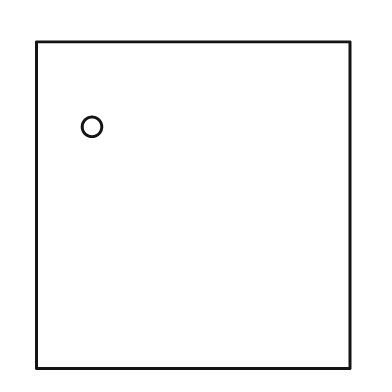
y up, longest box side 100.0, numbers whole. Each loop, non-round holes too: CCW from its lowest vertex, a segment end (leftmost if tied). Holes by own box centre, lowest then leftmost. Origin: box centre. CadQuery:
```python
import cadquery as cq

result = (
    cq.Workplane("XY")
    .moveTo(-48.0, -50.0)
    .lineTo(48.0, -50.0)
    .lineTo(48.0, 50.0)
    .lineTo(-48.0, 50.0)
    .close()
    .moveTo(-31.0, 24.0)
    .circle(3.0)
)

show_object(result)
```